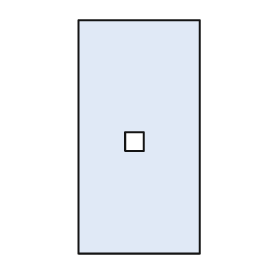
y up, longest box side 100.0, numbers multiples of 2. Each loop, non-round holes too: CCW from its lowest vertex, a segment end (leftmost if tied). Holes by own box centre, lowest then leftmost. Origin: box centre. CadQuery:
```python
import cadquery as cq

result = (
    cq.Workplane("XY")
    .moveTo(-26.0, -50.0)
    .lineTo(26.0, -50.0)
    .lineTo(26.0, 50.0)
    .lineTo(-26.0, 50.0)
    .close()
    .moveTo(-6.0, -6.0)
    .lineTo(2.0, -6.0)
    .lineTo(2.0, 2.0)
    .lineTo(-6.0, 2.0)
    .close()
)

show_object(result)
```